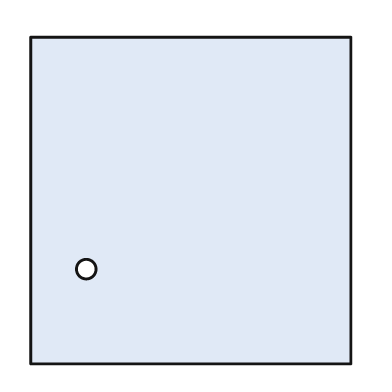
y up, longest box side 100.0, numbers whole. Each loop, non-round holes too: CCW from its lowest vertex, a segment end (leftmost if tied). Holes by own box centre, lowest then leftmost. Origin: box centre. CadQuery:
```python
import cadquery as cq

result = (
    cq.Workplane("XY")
    .moveTo(-49.0, -50.0)
    .lineTo(49.0, -50.0)
    .lineTo(49.0, 50.0)
    .lineTo(-49.0, 50.0)
    .close()
    .moveTo(-32.0, -21.0)
    .circle(3.0)
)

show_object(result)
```